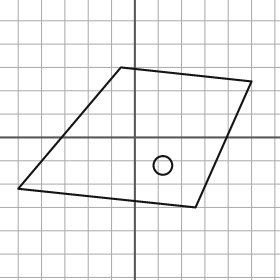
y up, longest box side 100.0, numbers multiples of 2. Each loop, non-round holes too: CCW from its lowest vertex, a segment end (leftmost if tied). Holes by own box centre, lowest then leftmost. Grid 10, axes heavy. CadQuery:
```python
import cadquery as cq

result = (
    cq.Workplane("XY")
    .moveTo(26.0, -30.0)
    .lineTo(50.0, 24.0)
    .lineTo(-6.0, 30.0)
    .lineTo(-50.0, -22.0)
    .close()
    .moveTo(12.0, -12.0)
    .circle(4.0)
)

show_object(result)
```